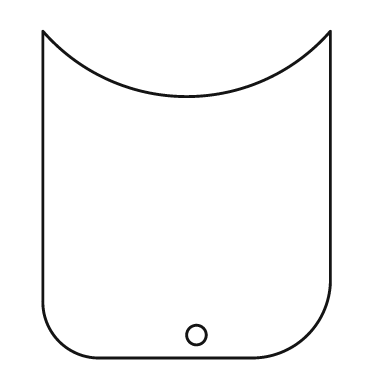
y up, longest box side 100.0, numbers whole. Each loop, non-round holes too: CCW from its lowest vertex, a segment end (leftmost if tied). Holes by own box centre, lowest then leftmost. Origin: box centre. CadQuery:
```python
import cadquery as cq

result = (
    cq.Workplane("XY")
    .moveTo(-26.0, -50.0)
    .lineTo(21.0, -50.0)
    .threePointArc((37.0, -43.0), (44.0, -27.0))
    .lineTo(44.0, 50.0)
    .threePointArc((0.0, 30.0), (-44.0, 50.0))
    .lineTo(-44.0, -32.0)
    .threePointArc((-39.0, -45.0), (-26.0, -50.0))
    .close()
    .moveTo(3.0, -43.0)
    .circle(3.0)
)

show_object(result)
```